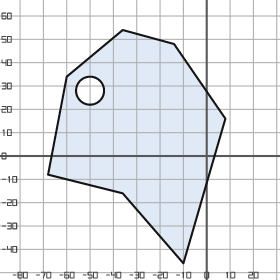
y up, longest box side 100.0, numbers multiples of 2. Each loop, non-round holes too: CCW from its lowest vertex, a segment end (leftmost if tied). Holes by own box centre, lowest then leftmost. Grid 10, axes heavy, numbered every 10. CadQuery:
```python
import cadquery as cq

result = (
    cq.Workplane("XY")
    .moveTo(-10.0, -46.0)
    .lineTo(8.0, 16.0)
    .lineTo(-14.0, 48.0)
    .lineTo(-36.0, 54.0)
    .lineTo(-60.0, 34.0)
    .lineTo(-68.0, -8.0)
    .lineTo(-36.0, -16.0)
    .close()
    .moveTo(-50.0, 28.0)
    .circle(6.0)
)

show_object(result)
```